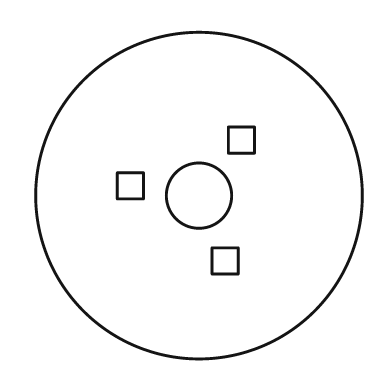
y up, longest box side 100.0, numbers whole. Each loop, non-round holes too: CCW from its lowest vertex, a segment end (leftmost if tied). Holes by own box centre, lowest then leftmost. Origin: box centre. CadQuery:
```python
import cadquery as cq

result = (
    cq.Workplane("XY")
    .moveTo(0.0, 0.0)
    .circle(50.0)
    .moveTo(4.0, -24.0)
    .lineTo(12.0, -24.0)
    .lineTo(12.0, -16.0)
    .lineTo(4.0, -16.0)
    .close()
    .moveTo(0.0, 0.0)
    .circle(10.0)
    .moveTo(-25.0, -1.0)
    .lineTo(-17.0, -1.0)
    .lineTo(-17.0, 7.0)
    .lineTo(-25.0, 7.0)
    .close()
    .moveTo(9.0, 13.0)
    .lineTo(17.0, 13.0)
    .lineTo(17.0, 21.0)
    .lineTo(9.0, 21.0)
    .close()
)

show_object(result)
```